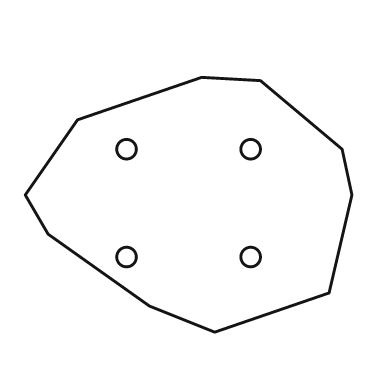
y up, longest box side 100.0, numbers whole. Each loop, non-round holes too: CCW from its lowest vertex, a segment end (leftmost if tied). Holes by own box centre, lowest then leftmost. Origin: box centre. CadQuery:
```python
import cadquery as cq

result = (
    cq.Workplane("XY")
    .moveTo(8.0, -39.0)
    .lineTo(43.0, -27.0)
    .lineTo(50.0, 3.0)
    .lineTo(47.0, 17.0)
    .lineTo(22.0, 38.0)
    .lineTo(4.0, 39.0)
    .lineTo(-34.0, 26.0)
    .lineTo(-50.0, 3.0)
    .lineTo(-43.0, -9.0)
    .lineTo(-12.0, -31.0)
    .close()
    .moveTo(-19.0, -16.0)
    .circle(3.0)
    .moveTo(19.0, -16.0)
    .circle(3.0)
    .moveTo(-19.0, 17.0)
    .circle(3.0)
    .moveTo(19.0, 17.0)
    .circle(3.0)
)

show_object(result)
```